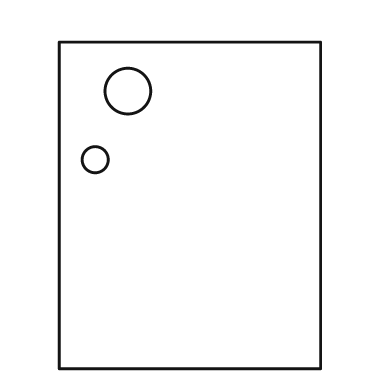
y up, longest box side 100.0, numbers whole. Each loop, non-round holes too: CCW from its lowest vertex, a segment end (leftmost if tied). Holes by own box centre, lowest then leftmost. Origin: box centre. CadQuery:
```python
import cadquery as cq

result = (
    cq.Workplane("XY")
    .moveTo(-40.0, -50.0)
    .lineTo(40.0, -50.0)
    .lineTo(40.0, 50.0)
    .lineTo(-40.0, 50.0)
    .close()
    .moveTo(-29.0, 14.0)
    .circle(4.0)
    .moveTo(-19.0, 35.0)
    .circle(7.0)
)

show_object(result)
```